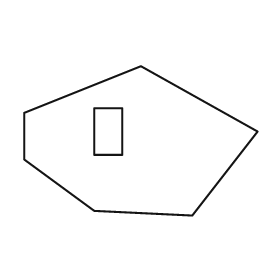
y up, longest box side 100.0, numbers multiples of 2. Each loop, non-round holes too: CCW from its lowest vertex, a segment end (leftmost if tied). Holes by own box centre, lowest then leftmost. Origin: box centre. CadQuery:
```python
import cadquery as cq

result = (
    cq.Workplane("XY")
    .moveTo(22.0, -32.0)
    .lineTo(50.0, 4.0)
    .lineTo(0.0, 32.0)
    .lineTo(-50.0, 12.0)
    .lineTo(-50.0, -8.0)
    .lineTo(-20.0, -30.0)
    .close()
    .moveTo(-20.0, -6.0)
    .lineTo(-8.0, -6.0)
    .lineTo(-8.0, 14.0)
    .lineTo(-20.0, 14.0)
    .close()
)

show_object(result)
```